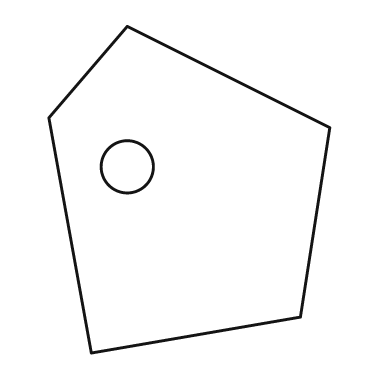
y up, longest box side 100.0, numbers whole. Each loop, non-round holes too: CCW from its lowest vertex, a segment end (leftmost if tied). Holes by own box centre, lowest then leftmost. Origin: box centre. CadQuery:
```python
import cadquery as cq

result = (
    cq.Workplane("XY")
    .moveTo(-30.0, -50.0)
    .lineTo(34.0, -39.0)
    .lineTo(43.0, 19.0)
    .lineTo(-19.0, 50.0)
    .lineTo(-43.0, 22.0)
    .close()
    .moveTo(-19.0, 7.0)
    .circle(8.0)
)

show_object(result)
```